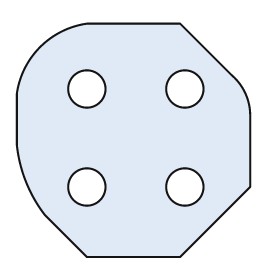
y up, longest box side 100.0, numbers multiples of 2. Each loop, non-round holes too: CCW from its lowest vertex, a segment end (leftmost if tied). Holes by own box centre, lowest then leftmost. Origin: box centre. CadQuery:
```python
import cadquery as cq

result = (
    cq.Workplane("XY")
    .moveTo(-20.0, -50.0)
    .lineTo(20.0, -50.0)
    .lineTo(50.0, -20.0)
    .lineTo(50.0, 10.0)
    .threePointArc((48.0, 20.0), (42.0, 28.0))
    .lineTo(20.0, 50.0)
    .lineTo(-20.0, 50.0)
    .threePointArc((-40.0, 40.0), (-50.0, 20.0))
    .lineTo(-50.0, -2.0)
    .threePointArc((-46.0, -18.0), (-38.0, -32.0))
    .close()
    .moveTo(-20.0, -20.0)
    .circle(8.0)
    .moveTo(22.0, -20.0)
    .circle(8.0)
    .moveTo(-20.0, 22.0)
    .circle(8.0)
    .moveTo(22.0, 22.0)
    .circle(8.0)
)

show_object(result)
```